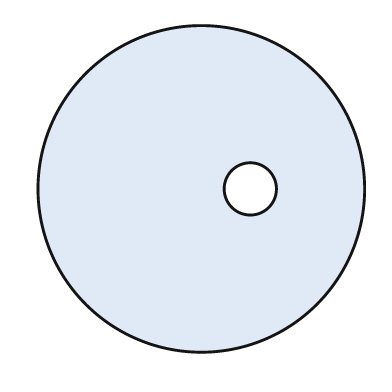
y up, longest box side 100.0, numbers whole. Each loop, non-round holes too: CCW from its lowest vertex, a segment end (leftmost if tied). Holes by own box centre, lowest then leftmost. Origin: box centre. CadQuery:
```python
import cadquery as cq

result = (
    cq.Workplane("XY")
    .moveTo(0.0, 0.0)
    .circle(50.0)
    .moveTo(15.0, 0.0)
    .circle(8.0)
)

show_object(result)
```